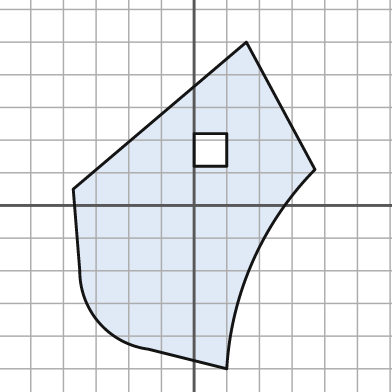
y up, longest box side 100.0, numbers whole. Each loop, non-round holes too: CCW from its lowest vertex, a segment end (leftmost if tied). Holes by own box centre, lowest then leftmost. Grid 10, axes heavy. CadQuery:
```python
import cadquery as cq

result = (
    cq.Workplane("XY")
    .moveTo(10.0, -50.0)
    .threePointArc((18.0, -17.0), (37.0, 11.0))
    .lineTo(16.0, 50.0)
    .lineTo(-37.0, 5.0)
    .lineTo(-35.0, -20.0)
    .threePointArc((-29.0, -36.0), (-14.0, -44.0))
    .close()
    .moveTo(0.0, 12.0)
    .lineTo(10.0, 12.0)
    .lineTo(10.0, 22.0)
    .lineTo(0.0, 22.0)
    .close()
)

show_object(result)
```